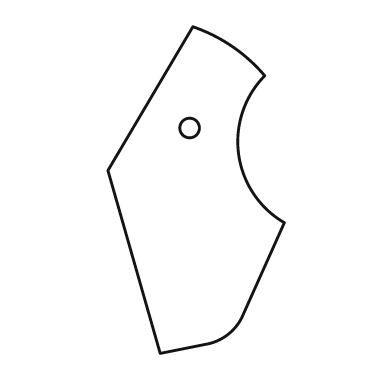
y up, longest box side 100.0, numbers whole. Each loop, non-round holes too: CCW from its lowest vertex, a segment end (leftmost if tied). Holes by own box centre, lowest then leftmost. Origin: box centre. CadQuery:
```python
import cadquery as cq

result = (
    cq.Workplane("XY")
    .moveTo(-11.0, -50.0)
    .lineTo(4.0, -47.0)
    .threePointArc((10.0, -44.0), (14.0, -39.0))
    .lineTo(27.0, -10.0)
    .threePointArc((13.0, 11.0), (21.0, 35.0))
    .threePointArc((11.0, 44.0), (-1.0, 50.0))
    .lineTo(-27.0, 6.0)
    .close()
    .moveTo(-2.0, 19.0)
    .circle(3.0)
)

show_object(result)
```